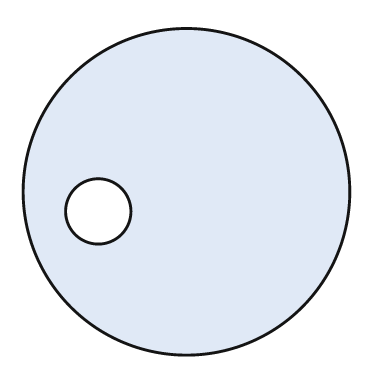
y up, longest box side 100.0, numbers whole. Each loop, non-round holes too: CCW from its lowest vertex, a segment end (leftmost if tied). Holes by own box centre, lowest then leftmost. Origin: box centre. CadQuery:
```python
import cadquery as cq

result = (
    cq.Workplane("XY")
    .moveTo(0.0, 0.0)
    .circle(50.0)
    .moveTo(-27.0, -6.0)
    .circle(10.0)
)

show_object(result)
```